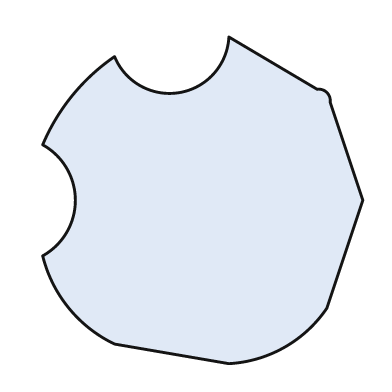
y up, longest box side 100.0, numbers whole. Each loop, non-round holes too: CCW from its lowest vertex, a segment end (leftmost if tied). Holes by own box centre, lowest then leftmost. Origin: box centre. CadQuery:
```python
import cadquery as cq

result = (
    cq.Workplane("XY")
    .moveTo(8.0, -50.0)
    .threePointArc((25.0, -45.0), (38.0, -33.0))
    .lineTo(49.0, 0.0)
    .lineTo(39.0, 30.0)
    .threePointArc((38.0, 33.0), (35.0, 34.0))
    .lineTo(8.0, 50.0)
    .threePointArc((-7.0, 33.0), (-27.0, 44.0))
    .threePointArc((-40.0, 32.0), (-49.0, 17.0))
    .threePointArc((-39.0, 0.0), (-49.0, -17.0))
    .threePointArc((-41.0, -33.0), (-27.0, -44.0))
    .close()
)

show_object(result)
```